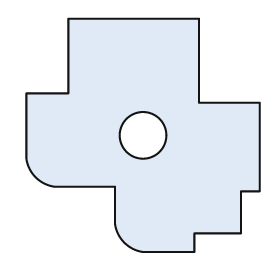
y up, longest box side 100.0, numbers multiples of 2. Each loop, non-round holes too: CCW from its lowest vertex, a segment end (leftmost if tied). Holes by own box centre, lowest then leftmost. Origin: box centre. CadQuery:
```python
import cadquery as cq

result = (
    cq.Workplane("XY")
    .moveTo(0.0, -50.0)
    .lineTo(22.0, -50.0)
    .lineTo(22.0, -42.0)
    .lineTo(42.0, -42.0)
    .lineTo(42.0, -24.0)
    .lineTo(50.0, -24.0)
    .lineTo(50.0, 14.0)
    .lineTo(24.0, 14.0)
    .lineTo(24.0, 50.0)
    .lineTo(-32.0, 50.0)
    .lineTo(-32.0, 18.0)
    .lineTo(-50.0, 18.0)
    .lineTo(-50.0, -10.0)
    .threePointArc((-46.0, -18.0), (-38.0, -22.0))
    .lineTo(-12.0, -22.0)
    .lineTo(-12.0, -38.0)
    .threePointArc((-8.0, -46.0), (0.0, -50.0))
    .close()
    .moveTo(0.0, 0.0)
    .circle(10.0)
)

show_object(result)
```